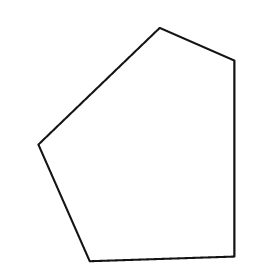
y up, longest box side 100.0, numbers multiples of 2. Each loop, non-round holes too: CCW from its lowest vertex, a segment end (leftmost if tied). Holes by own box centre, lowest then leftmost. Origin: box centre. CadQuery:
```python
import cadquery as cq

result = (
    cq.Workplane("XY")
    .moveTo(-20.0, -50.0)
    .lineTo(42.0, -48.0)
    .lineTo(42.0, 36.0)
    .lineTo(10.0, 50.0)
    .lineTo(-42.0, 0.0)
    .close()
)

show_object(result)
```